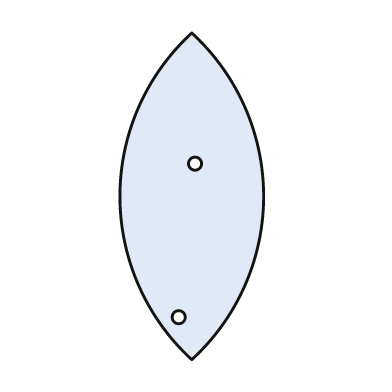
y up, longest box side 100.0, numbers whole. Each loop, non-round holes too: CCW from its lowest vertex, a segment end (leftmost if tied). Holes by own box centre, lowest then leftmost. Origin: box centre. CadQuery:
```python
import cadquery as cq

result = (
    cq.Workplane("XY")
    .moveTo(0.0, -50.0)
    .threePointArc((22.0, 0.0), (0.0, 50.0))
    .threePointArc((-22.0, 0.0), (0.0, -50.0))
    .close()
    .moveTo(-4.0, -37.0)
    .circle(2.0)
    .moveTo(1.0, 10.0)
    .circle(2.0)
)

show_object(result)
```